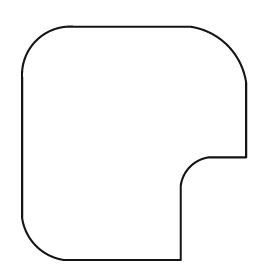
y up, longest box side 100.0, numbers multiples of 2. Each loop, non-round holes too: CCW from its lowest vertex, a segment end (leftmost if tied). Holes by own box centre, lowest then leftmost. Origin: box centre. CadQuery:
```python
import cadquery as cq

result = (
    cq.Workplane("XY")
    .moveTo(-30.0, -50.0)
    .lineTo(20.0, -50.0)
    .lineTo(20.0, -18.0)
    .threePointArc((24.0, -10.0), (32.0, -6.0))
    .lineTo(48.0, -6.0)
    .lineTo(48.0, 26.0)
    .threePointArc((40.0, 42.0), (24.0, 50.0))
    .lineTo(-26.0, 50.0)
    .threePointArc((-42.0, 44.0), (-48.0, 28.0))
    .lineTo(-48.0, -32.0)
    .threePointArc((-42.0, -44.0), (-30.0, -50.0))
    .close()
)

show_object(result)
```